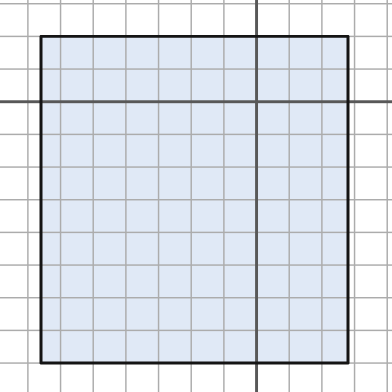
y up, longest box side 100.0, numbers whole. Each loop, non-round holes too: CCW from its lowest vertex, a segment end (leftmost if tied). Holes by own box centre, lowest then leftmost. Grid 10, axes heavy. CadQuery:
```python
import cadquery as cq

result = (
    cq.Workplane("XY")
    .moveTo(-66.0, -80.0)
    .lineTo(28.0, -80.0)
    .lineTo(28.0, 20.0)
    .lineTo(-66.0, 20.0)
    .close()
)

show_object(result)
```